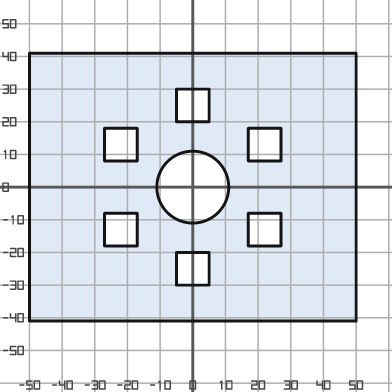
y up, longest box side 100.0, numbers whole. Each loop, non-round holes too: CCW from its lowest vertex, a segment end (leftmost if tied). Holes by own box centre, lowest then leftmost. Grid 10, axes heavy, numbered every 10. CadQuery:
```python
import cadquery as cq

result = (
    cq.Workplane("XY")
    .moveTo(-50.0, -41.0)
    .lineTo(50.0, -41.0)
    .lineTo(50.0, 41.0)
    .lineTo(-50.0, 41.0)
    .close()
    .moveTo(-5.0, -30.0)
    .lineTo(5.0, -30.0)
    .lineTo(5.0, -20.0)
    .lineTo(-5.0, -20.0)
    .close()
    .moveTo(-27.0, -18.0)
    .lineTo(-17.0, -18.0)
    .lineTo(-17.0, -8.0)
    .lineTo(-27.0, -8.0)
    .close()
    .moveTo(17.0, -18.0)
    .lineTo(27.0, -18.0)
    .lineTo(27.0, -8.0)
    .lineTo(17.0, -8.0)
    .close()
    .moveTo(0.0, 0.0)
    .circle(11.0)
    .moveTo(-27.0, 8.0)
    .lineTo(-17.0, 8.0)
    .lineTo(-17.0, 18.0)
    .lineTo(-27.0, 18.0)
    .close()
    .moveTo(17.0, 8.0)
    .lineTo(27.0, 8.0)
    .lineTo(27.0, 18.0)
    .lineTo(17.0, 18.0)
    .close()
    .moveTo(-5.0, 20.0)
    .lineTo(5.0, 20.0)
    .lineTo(5.0, 30.0)
    .lineTo(-5.0, 30.0)
    .close()
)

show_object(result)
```